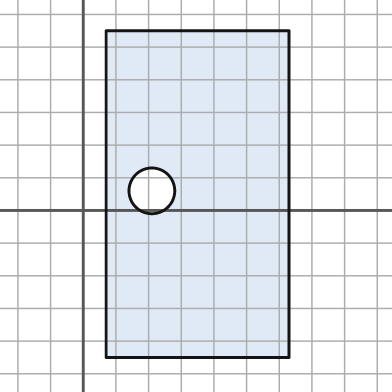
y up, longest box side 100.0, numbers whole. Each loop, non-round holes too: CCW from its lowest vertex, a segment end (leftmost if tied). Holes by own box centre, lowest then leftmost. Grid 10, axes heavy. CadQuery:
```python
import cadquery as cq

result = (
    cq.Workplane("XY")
    .moveTo(7.0, -45.0)
    .lineTo(63.0, -45.0)
    .lineTo(63.0, 55.0)
    .lineTo(7.0, 55.0)
    .close()
    .moveTo(21.0, 6.0)
    .circle(7.0)
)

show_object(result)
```